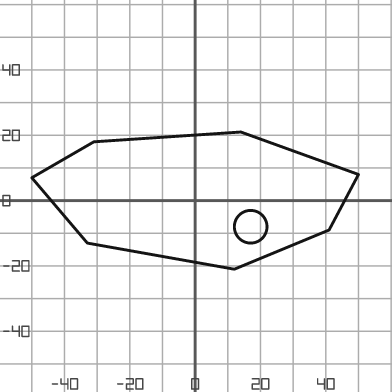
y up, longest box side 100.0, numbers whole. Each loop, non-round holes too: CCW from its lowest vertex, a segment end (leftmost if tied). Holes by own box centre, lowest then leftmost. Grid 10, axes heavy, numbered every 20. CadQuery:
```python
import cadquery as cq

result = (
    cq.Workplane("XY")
    .moveTo(12.0, -21.0)
    .lineTo(41.0, -9.0)
    .lineTo(50.0, 8.0)
    .lineTo(14.0, 21.0)
    .lineTo(-31.0, 18.0)
    .lineTo(-50.0, 7.0)
    .lineTo(-33.0, -13.0)
    .close()
    .moveTo(17.0, -8.0)
    .circle(5.0)
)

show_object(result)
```